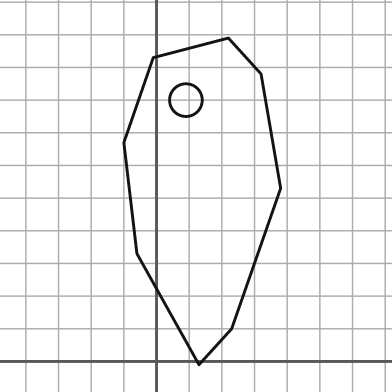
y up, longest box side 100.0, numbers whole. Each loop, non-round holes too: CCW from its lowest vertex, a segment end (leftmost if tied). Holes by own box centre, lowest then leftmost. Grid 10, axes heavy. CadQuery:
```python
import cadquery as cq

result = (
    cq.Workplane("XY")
    .moveTo(13.0, -1.0)
    .lineTo(23.0, 10.0)
    .lineTo(38.0, 53.0)
    .lineTo(32.0, 88.0)
    .lineTo(22.0, 99.0)
    .lineTo(-1.0, 93.0)
    .lineTo(-10.0, 67.0)
    .lineTo(-6.0, 33.0)
    .close()
    .moveTo(9.0, 80.0)
    .circle(5.0)
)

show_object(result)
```